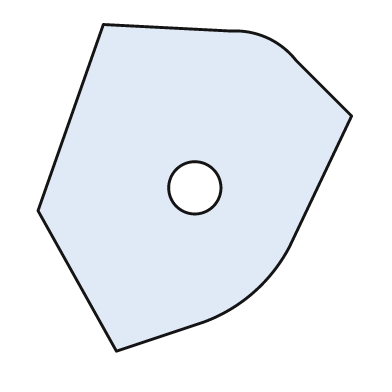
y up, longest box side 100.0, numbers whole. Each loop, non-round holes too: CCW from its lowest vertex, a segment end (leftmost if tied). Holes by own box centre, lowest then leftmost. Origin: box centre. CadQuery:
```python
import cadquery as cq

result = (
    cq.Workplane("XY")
    .moveTo(-24.0, -50.0)
    .lineTo(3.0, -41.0)
    .threePointArc((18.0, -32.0), (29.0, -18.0))
    .lineTo(48.0, 22.0)
    .lineTo(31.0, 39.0)
    .threePointArc((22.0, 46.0), (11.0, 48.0))
    .lineTo(-28.0, 50.0)
    .lineTo(-48.0, -7.0)
    .close()
    .moveTo(0.0, 0.0)
    .circle(8.0)
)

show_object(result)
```